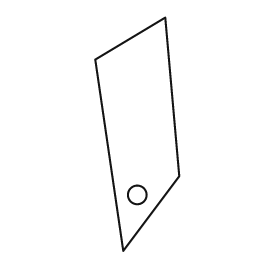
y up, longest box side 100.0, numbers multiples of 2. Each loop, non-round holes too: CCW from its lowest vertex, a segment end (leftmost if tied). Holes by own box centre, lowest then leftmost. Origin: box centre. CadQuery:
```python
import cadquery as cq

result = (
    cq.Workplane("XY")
    .moveTo(-6.0, -50.0)
    .lineTo(18.0, -18.0)
    .lineTo(12.0, 50.0)
    .lineTo(-18.0, 32.0)
    .close()
    .moveTo(0.0, -26.0)
    .circle(4.0)
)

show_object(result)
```